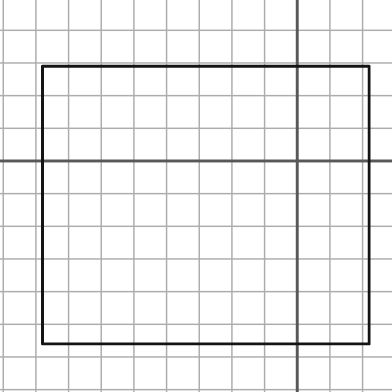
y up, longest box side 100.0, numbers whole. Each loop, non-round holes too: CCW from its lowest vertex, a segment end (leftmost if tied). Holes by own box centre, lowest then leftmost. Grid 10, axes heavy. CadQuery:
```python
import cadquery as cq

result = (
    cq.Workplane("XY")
    .moveTo(-78.0, -56.0)
    .lineTo(22.0, -56.0)
    .lineTo(22.0, 29.0)
    .lineTo(-78.0, 29.0)
    .close()
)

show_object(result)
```